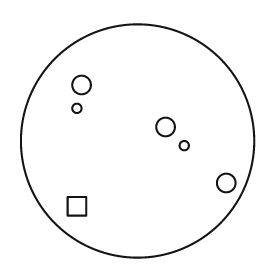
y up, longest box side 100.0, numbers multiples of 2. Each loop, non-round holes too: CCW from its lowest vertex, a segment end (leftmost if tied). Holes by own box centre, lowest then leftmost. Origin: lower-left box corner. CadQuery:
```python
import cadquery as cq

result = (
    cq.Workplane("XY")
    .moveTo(50.0, 50.0)
    .circle(50.0)
    .moveTo(20.0, 18.0)
    .lineTo(28.0, 18.0)
    .lineTo(28.0, 26.0)
    .lineTo(20.0, 26.0)
    .close()
    .moveTo(88.0, 32.0)
    .circle(4.0)
    .moveTo(70.0, 48.0)
    .circle(2.0)
    .moveTo(62.0, 56.0)
    .circle(4.0)
    .moveTo(24.0, 64.0)
    .circle(2.0)
    .moveTo(26.0, 74.0)
    .circle(4.0)
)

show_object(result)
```